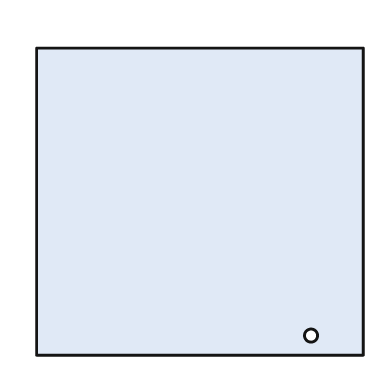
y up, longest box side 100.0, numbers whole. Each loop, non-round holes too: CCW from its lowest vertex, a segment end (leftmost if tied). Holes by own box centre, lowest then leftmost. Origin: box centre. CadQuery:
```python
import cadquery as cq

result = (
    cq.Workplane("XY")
    .moveTo(-50.0, -47.0)
    .lineTo(50.0, -47.0)
    .lineTo(50.0, 47.0)
    .lineTo(-50.0, 47.0)
    .close()
    .moveTo(34.0, -41.0)
    .circle(2.0)
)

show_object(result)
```